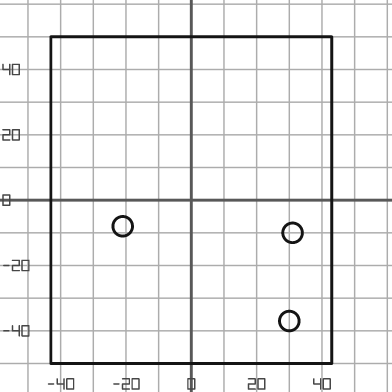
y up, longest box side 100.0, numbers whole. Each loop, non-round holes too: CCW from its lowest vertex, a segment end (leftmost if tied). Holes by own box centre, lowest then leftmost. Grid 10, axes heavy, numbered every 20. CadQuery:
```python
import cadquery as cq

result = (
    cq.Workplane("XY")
    .moveTo(-43.0, -50.0)
    .lineTo(43.0, -50.0)
    .lineTo(43.0, 50.0)
    .lineTo(-43.0, 50.0)
    .close()
    .moveTo(30.0, -37.0)
    .circle(3.0)
    .moveTo(31.0, -10.0)
    .circle(3.0)
    .moveTo(-21.0, -8.0)
    .circle(3.0)
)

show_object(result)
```